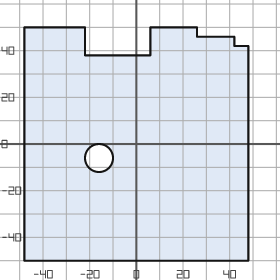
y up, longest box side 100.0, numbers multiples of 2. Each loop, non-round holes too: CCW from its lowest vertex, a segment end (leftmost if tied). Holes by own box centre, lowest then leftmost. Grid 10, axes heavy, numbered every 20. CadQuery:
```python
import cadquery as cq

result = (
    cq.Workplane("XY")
    .moveTo(-48.0, -50.0)
    .lineTo(48.0, -50.0)
    .lineTo(48.0, 42.0)
    .lineTo(42.0, 42.0)
    .lineTo(42.0, 46.0)
    .lineTo(26.0, 46.0)
    .lineTo(26.0, 50.0)
    .lineTo(6.0, 50.0)
    .lineTo(6.0, 38.0)
    .lineTo(-22.0, 38.0)
    .lineTo(-22.0, 50.0)
    .lineTo(-48.0, 50.0)
    .close()
    .moveTo(-16.0, -6.0)
    .circle(6.0)
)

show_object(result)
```